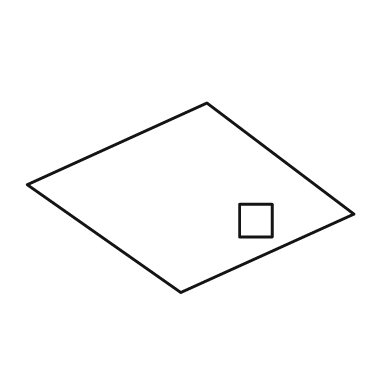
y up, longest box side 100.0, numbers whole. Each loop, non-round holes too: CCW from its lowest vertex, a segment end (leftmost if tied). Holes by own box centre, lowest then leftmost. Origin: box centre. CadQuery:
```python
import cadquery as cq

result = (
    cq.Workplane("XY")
    .moveTo(-3.0, -29.0)
    .lineTo(50.0, -5.0)
    .lineTo(5.0, 29.0)
    .lineTo(-50.0, 4.0)
    .close()
    .moveTo(15.0, -12.0)
    .lineTo(25.0, -12.0)
    .lineTo(25.0, -2.0)
    .lineTo(15.0, -2.0)
    .close()
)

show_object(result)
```